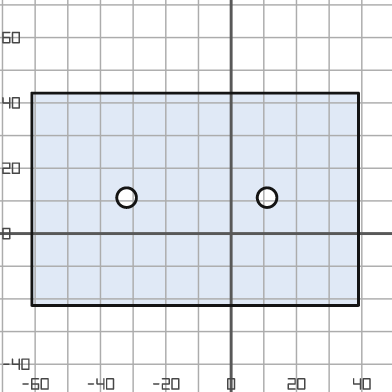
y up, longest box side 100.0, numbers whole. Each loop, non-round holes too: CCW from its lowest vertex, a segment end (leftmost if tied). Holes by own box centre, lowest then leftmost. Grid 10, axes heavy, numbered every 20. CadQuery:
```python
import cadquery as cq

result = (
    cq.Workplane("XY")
    .moveTo(-61.0, -22.0)
    .lineTo(39.0, -22.0)
    .lineTo(39.0, 43.0)
    .lineTo(-61.0, 43.0)
    .close()
    .moveTo(-32.0, 11.0)
    .circle(3.0)
    .moveTo(11.0, 11.0)
    .circle(3.0)
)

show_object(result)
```